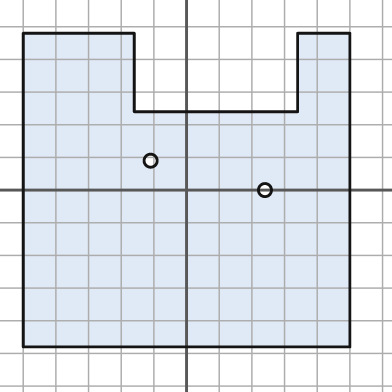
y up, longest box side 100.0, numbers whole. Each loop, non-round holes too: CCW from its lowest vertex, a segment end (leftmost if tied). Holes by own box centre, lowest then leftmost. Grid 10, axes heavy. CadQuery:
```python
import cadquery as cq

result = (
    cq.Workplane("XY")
    .moveTo(-50.0, -48.0)
    .lineTo(50.0, -48.0)
    .lineTo(50.0, 48.0)
    .lineTo(34.0, 48.0)
    .lineTo(34.0, 24.0)
    .lineTo(-16.0, 24.0)
    .lineTo(-16.0, 48.0)
    .lineTo(-50.0, 48.0)
    .close()
    .moveTo(24.0, 0.0)
    .circle(2.0)
    .moveTo(-11.0, 9.0)
    .circle(2.0)
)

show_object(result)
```